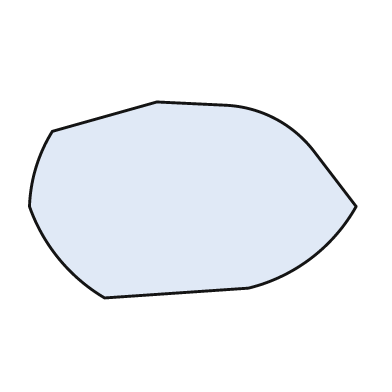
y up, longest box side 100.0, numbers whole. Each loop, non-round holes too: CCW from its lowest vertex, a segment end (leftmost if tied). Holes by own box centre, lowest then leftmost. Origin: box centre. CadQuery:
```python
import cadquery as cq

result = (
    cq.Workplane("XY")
    .moveTo(-27.0, -30.0)
    .lineTo(17.0, -27.0)
    .threePointArc((36.0, -18.0), (50.0, -2.0))
    .lineTo(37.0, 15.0)
    .threePointArc((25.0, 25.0), (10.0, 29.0))
    .lineTo(-11.0, 30.0)
    .lineTo(-43.0, 21.0)
    .threePointArc((-48.0, 10.0), (-50.0, -2.0))
    .threePointArc((-41.0, -18.0), (-27.0, -30.0))
    .close()
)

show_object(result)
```